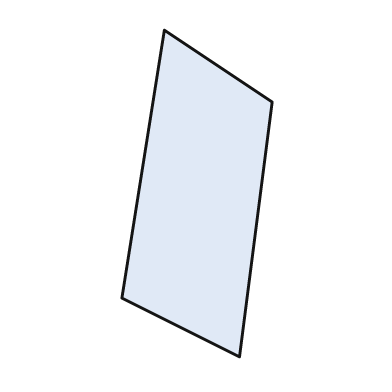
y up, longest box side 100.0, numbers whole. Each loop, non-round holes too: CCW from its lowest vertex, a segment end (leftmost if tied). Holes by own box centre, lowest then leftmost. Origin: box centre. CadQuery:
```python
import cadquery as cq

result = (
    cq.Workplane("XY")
    .moveTo(13.0, -50.0)
    .lineTo(23.0, 28.0)
    .lineTo(-10.0, 50.0)
    .lineTo(-23.0, -32.0)
    .close()
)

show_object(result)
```